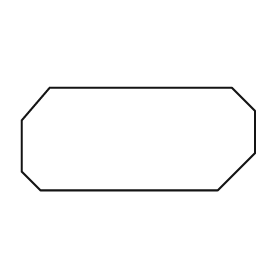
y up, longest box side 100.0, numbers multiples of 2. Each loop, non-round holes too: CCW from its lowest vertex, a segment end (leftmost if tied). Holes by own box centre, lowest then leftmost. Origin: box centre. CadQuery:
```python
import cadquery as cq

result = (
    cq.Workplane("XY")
    .moveTo(-42.0, -22.0)
    .lineTo(34.0, -22.0)
    .lineTo(50.0, -6.0)
    .lineTo(50.0, 12.0)
    .lineTo(40.0, 22.0)
    .lineTo(-38.0, 22.0)
    .lineTo(-50.0, 8.0)
    .lineTo(-50.0, -14.0)
    .close()
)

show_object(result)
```